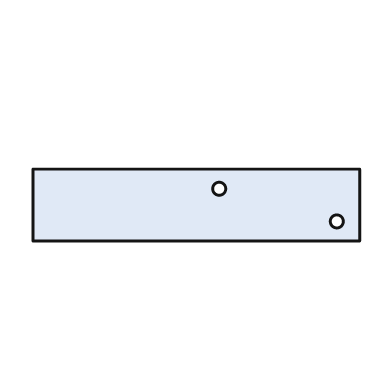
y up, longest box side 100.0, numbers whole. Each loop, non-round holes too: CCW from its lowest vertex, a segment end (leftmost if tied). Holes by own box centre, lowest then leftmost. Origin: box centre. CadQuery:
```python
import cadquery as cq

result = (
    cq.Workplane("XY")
    .moveTo(-50.0, -11.0)
    .lineTo(50.0, -11.0)
    .lineTo(50.0, 11.0)
    .lineTo(-50.0, 11.0)
    .close()
    .moveTo(43.0, -5.0)
    .circle(2.0)
    .moveTo(7.0, 5.0)
    .circle(2.0)
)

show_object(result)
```